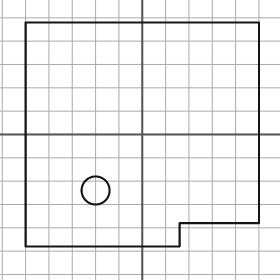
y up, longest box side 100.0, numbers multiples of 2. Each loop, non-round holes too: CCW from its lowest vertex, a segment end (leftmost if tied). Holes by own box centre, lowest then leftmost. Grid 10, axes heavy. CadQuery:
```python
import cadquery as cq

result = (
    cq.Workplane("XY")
    .moveTo(-50.0, -48.0)
    .lineTo(16.0, -48.0)
    .lineTo(16.0, -38.0)
    .lineTo(50.0, -38.0)
    .lineTo(50.0, 48.0)
    .lineTo(-50.0, 48.0)
    .close()
    .moveTo(-20.0, -24.0)
    .circle(6.0)
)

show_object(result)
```